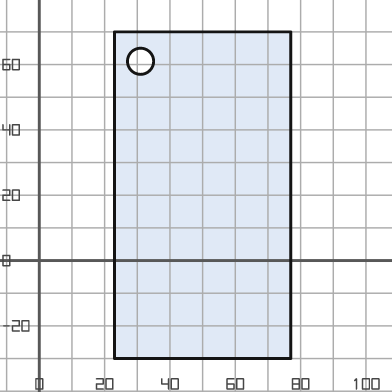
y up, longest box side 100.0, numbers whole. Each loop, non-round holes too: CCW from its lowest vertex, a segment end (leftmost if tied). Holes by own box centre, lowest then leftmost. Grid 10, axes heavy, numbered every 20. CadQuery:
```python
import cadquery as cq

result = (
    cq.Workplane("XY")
    .moveTo(23.0, -30.0)
    .lineTo(77.0, -30.0)
    .lineTo(77.0, 70.0)
    .lineTo(23.0, 70.0)
    .close()
    .moveTo(31.0, 61.0)
    .circle(4.0)
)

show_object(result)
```